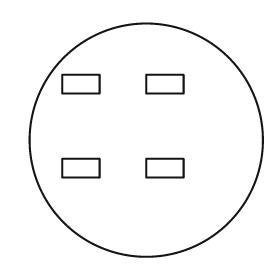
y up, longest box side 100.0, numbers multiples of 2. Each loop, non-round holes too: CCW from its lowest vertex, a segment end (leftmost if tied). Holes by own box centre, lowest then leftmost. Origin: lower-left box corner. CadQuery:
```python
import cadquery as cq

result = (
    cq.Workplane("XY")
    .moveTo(50.0, 50.0)
    .circle(50.0)
    .moveTo(14.0, 34.0)
    .lineTo(30.0, 34.0)
    .lineTo(30.0, 42.0)
    .lineTo(14.0, 42.0)
    .close()
    .moveTo(50.0, 34.0)
    .lineTo(66.0, 34.0)
    .lineTo(66.0, 42.0)
    .lineTo(50.0, 42.0)
    .close()
    .moveTo(14.0, 70.0)
    .lineTo(30.0, 70.0)
    .lineTo(30.0, 78.0)
    .lineTo(14.0, 78.0)
    .close()
    .moveTo(50.0, 70.0)
    .lineTo(66.0, 70.0)
    .lineTo(66.0, 78.0)
    .lineTo(50.0, 78.0)
    .close()
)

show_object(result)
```